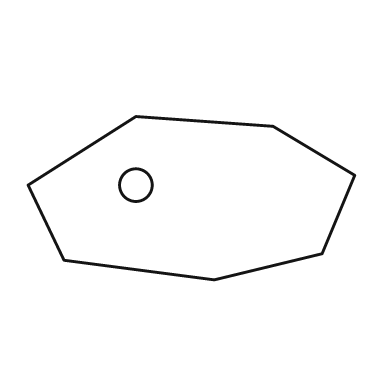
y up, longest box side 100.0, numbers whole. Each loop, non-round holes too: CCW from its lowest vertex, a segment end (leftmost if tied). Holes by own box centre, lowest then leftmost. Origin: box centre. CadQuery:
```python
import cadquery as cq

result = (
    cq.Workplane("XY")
    .moveTo(7.0, -25.0)
    .lineTo(40.0, -17.0)
    .lineTo(50.0, 7.0)
    .lineTo(25.0, 22.0)
    .lineTo(-17.0, 25.0)
    .lineTo(-50.0, 4.0)
    .lineTo(-39.0, -19.0)
    .close()
    .moveTo(-17.0, 4.0)
    .circle(5.0)
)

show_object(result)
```